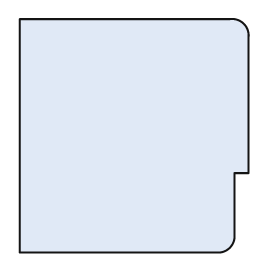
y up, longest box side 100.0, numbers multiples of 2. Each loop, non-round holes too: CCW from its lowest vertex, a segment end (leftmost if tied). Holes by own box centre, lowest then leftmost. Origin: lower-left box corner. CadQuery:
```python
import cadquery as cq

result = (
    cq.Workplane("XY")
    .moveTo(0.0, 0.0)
    .lineTo(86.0, 0.0)
    .threePointArc((90.0, 2.0), (92.0, 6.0))
    .lineTo(92.0, 34.0)
    .lineTo(98.0, 34.0)
    .lineTo(98.0, 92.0)
    .threePointArc((96.0, 98.0), (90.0, 100.0))
    .lineTo(0.0, 100.0)
    .close()
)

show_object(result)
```